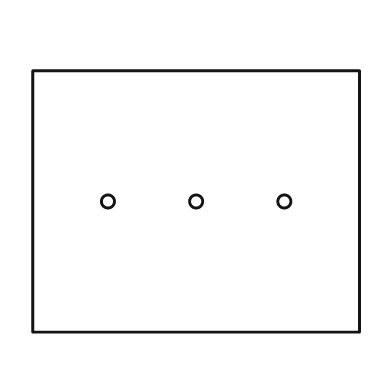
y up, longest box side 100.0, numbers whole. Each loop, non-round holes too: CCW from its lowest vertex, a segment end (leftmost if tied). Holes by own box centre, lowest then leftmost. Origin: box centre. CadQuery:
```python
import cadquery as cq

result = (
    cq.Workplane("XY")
    .moveTo(-50.0, -40.0)
    .lineTo(50.0, -40.0)
    .lineTo(50.0, 40.0)
    .lineTo(-50.0, 40.0)
    .close()
    .moveTo(-27.0, 0.0)
    .circle(2.0)
    .moveTo(0.0, 0.0)
    .circle(2.0)
    .moveTo(27.0, 0.0)
    .circle(2.0)
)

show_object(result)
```